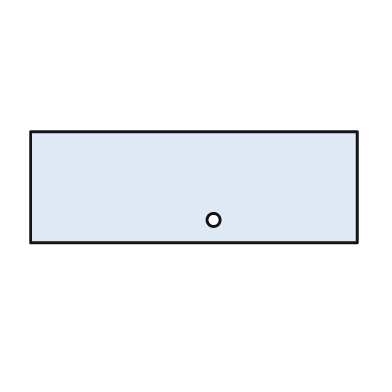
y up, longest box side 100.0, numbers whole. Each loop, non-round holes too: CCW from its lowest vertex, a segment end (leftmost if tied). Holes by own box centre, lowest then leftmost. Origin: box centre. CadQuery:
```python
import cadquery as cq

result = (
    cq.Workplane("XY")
    .moveTo(-50.0, -17.0)
    .lineTo(50.0, -17.0)
    .lineTo(50.0, 17.0)
    .lineTo(-50.0, 17.0)
    .close()
    .moveTo(6.0, -10.0)
    .circle(2.0)
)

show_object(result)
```